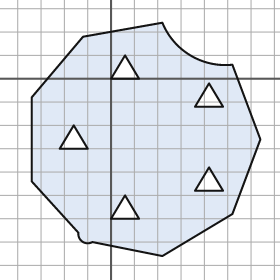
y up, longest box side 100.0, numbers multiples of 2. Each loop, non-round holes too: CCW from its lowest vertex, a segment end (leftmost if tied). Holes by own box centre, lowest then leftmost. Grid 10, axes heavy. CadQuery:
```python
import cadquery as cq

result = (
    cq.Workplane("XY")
    .moveTo(22.0, -76.0)
    .lineTo(52.0, -58.0)
    .lineTo(64.0, -26.0)
    .lineTo(52.0, 6.0)
    .threePointArc((34.0, 10.0), (22.0, 24.0))
    .lineTo(-12.0, 18.0)
    .lineTo(-34.0, -8.0)
    .lineTo(-34.0, -44.0)
    .lineTo(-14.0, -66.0)
    .threePointArc((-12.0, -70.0), (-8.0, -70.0))
    .close()
    .moveTo(0.0, -60.0)
    .lineTo(12.0, -60.0)
    .lineTo(6.0, -50.0)
    .close()
    .moveTo(36.0, -48.0)
    .lineTo(48.0, -48.0)
    .lineTo(42.0, -38.0)
    .close()
    .moveTo(-22.0, -30.0)
    .lineTo(-10.0, -30.0)
    .lineTo(-16.0, -20.0)
    .close()
    .moveTo(36.0, -12.0)
    .lineTo(48.0, -12.0)
    .lineTo(42.0, -2.0)
    .close()
    .moveTo(0.0, 0.0)
    .lineTo(12.0, 0.0)
    .lineTo(6.0, 10.0)
    .close()
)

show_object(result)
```